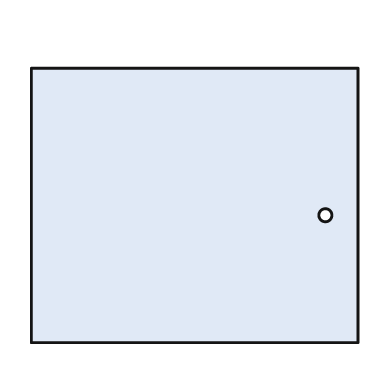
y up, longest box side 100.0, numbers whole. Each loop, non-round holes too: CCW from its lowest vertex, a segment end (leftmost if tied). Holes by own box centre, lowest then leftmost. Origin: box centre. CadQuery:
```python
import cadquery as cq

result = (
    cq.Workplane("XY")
    .moveTo(-50.0, -42.0)
    .lineTo(50.0, -42.0)
    .lineTo(50.0, 42.0)
    .lineTo(-50.0, 42.0)
    .close()
    .moveTo(40.0, -3.0)
    .circle(2.0)
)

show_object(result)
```